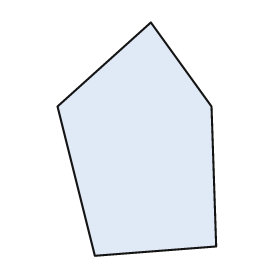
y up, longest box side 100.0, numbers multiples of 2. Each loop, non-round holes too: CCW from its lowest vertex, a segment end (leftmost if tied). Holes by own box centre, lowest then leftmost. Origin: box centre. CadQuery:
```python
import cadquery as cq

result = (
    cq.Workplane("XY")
    .moveTo(-18.0, -50.0)
    .lineTo(34.0, -46.0)
    .lineTo(32.0, 14.0)
    .lineTo(6.0, 50.0)
    .lineTo(-34.0, 14.0)
    .close()
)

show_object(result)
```